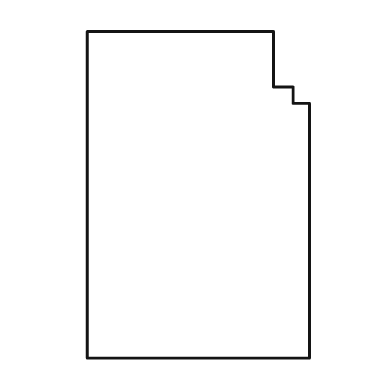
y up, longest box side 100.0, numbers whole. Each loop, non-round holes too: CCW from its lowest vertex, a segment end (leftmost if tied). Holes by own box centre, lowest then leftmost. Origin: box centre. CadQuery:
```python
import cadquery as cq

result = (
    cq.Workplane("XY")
    .moveTo(-34.0, -50.0)
    .lineTo(34.0, -50.0)
    .lineTo(34.0, 28.0)
    .lineTo(29.0, 28.0)
    .lineTo(29.0, 33.0)
    .lineTo(23.0, 33.0)
    .lineTo(23.0, 50.0)
    .lineTo(-34.0, 50.0)
    .close()
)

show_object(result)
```